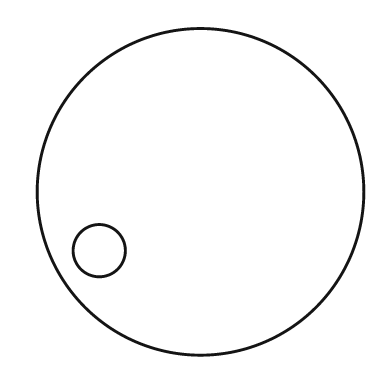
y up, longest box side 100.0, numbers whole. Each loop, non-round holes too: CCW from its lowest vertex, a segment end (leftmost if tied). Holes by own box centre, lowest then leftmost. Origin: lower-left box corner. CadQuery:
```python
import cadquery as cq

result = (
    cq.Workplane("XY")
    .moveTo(50.0, 50.0)
    .circle(50.0)
    .moveTo(19.0, 32.0)
    .circle(8.0)
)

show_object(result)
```